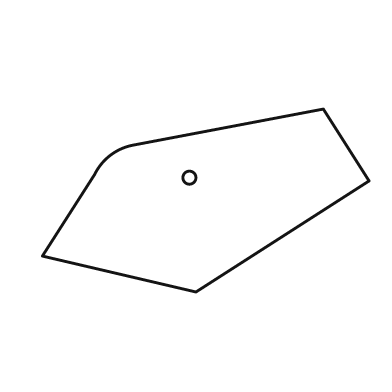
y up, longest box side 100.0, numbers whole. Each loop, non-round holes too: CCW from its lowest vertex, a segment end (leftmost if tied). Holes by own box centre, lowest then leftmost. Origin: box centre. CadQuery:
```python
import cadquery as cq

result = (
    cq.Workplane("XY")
    .moveTo(-3.0, -28.0)
    .lineTo(50.0, 6.0)
    .lineTo(36.0, 28.0)
    .lineTo(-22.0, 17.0)
    .threePointArc((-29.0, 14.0), (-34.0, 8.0))
    .lineTo(-50.0, -17.0)
    .close()
    .moveTo(-5.0, 7.0)
    .circle(2.0)
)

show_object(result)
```